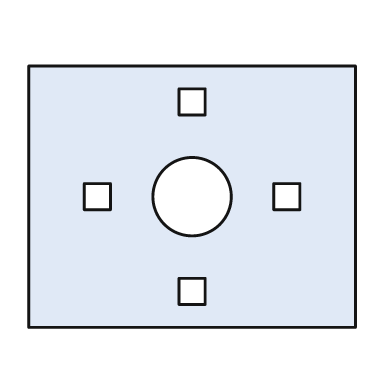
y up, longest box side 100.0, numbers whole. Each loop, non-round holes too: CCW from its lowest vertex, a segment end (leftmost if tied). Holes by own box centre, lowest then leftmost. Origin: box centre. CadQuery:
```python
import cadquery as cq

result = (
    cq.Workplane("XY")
    .moveTo(-50.0, -40.0)
    .lineTo(50.0, -40.0)
    .lineTo(50.0, 40.0)
    .lineTo(-50.0, 40.0)
    .close()
    .moveTo(-4.0, -33.0)
    .lineTo(4.0, -33.0)
    .lineTo(4.0, -25.0)
    .lineTo(-4.0, -25.0)
    .close()
    .moveTo(-33.0, -4.0)
    .lineTo(-25.0, -4.0)
    .lineTo(-25.0, 4.0)
    .lineTo(-33.0, 4.0)
    .close()
    .moveTo(0.0, 0.0)
    .circle(12.0)
    .moveTo(25.0, -4.0)
    .lineTo(33.0, -4.0)
    .lineTo(33.0, 4.0)
    .lineTo(25.0, 4.0)
    .close()
    .moveTo(-4.0, 25.0)
    .lineTo(4.0, 25.0)
    .lineTo(4.0, 33.0)
    .lineTo(-4.0, 33.0)
    .close()
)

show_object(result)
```